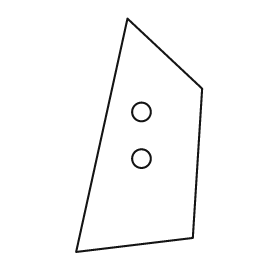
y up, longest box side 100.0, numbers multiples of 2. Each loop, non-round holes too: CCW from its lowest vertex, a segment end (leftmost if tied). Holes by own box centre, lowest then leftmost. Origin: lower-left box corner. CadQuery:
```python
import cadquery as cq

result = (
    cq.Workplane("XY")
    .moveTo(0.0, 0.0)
    .lineTo(50.0, 6.0)
    .lineTo(54.0, 70.0)
    .lineTo(22.0, 100.0)
    .close()
    .moveTo(28.0, 40.0)
    .circle(4.0)
    .moveTo(28.0, 60.0)
    .circle(4.0)
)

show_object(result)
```